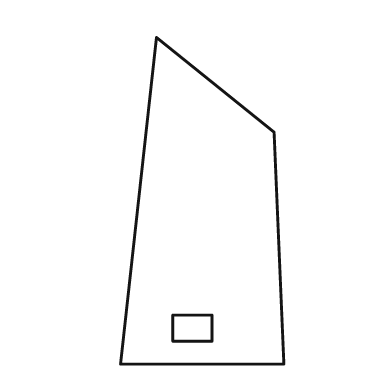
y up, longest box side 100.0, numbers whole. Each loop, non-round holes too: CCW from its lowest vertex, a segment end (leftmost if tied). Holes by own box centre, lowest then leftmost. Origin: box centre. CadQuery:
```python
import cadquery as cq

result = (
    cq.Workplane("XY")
    .moveTo(-25.0, -50.0)
    .lineTo(25.0, -50.0)
    .lineTo(22.0, 21.0)
    .lineTo(-14.0, 50.0)
    .close()
    .moveTo(-9.0, -43.0)
    .lineTo(3.0, -43.0)
    .lineTo(3.0, -35.0)
    .lineTo(-9.0, -35.0)
    .close()
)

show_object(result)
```